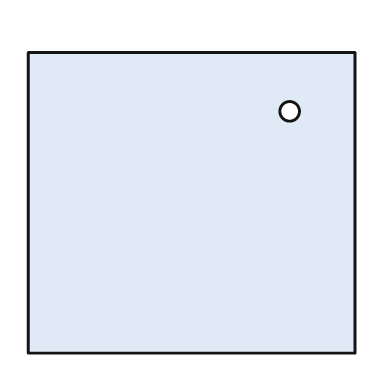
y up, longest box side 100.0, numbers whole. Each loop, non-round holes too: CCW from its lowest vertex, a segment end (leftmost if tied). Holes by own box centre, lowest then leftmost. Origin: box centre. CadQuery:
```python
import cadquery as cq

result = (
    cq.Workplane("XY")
    .moveTo(-50.0, -46.0)
    .lineTo(50.0, -46.0)
    .lineTo(50.0, 46.0)
    .lineTo(-50.0, 46.0)
    .close()
    .moveTo(30.0, 28.0)
    .circle(3.0)
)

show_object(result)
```